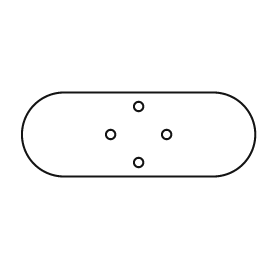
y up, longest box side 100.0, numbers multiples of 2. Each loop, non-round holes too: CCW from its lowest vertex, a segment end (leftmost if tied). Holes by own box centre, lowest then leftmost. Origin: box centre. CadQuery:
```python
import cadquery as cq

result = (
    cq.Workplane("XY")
    .moveTo(-32.0, -18.0)
    .lineTo(32.0, -18.0)
    .threePointArc((50.0, 0.0), (32.0, 18.0))
    .lineTo(-32.0, 18.0)
    .threePointArc((-50.0, 0.0), (-32.0, -18.0))
    .close()
    .moveTo(0.0, -12.0)
    .circle(2.0)
    .moveTo(-12.0, 0.0)
    .circle(2.0)
    .moveTo(12.0, 0.0)
    .circle(2.0)
    .moveTo(0.0, 12.0)
    .circle(2.0)
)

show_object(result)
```